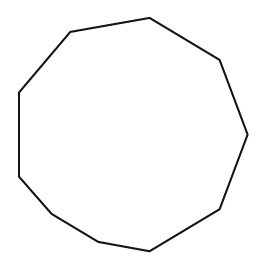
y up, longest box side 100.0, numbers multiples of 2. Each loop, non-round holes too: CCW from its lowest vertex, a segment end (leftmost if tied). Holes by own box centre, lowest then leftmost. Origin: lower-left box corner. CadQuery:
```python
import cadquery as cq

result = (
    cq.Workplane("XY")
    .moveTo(56.0, 0.0)
    .lineTo(86.0, 18.0)
    .lineTo(98.0, 50.0)
    .lineTo(86.0, 82.0)
    .lineTo(56.0, 100.0)
    .lineTo(22.0, 94.0)
    .lineTo(0.0, 68.0)
    .lineTo(0.0, 32.0)
    .lineTo(14.0, 16.0)
    .lineTo(34.0, 4.0)
    .close()
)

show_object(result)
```